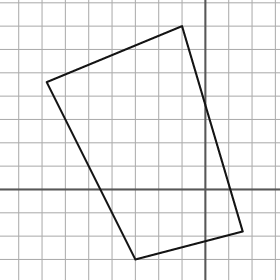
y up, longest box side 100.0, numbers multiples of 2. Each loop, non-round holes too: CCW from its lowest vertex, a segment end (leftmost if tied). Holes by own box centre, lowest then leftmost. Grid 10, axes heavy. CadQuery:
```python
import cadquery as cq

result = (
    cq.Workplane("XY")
    .moveTo(-30.0, -30.0)
    .lineTo(16.0, -18.0)
    .lineTo(-10.0, 70.0)
    .lineTo(-68.0, 46.0)
    .close()
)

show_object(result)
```